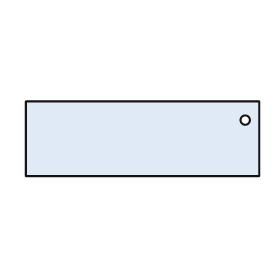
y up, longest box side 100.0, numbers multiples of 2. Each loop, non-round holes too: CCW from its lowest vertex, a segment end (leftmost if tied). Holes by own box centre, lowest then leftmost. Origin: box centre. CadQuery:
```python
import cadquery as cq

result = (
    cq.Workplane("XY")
    .moveTo(-50.0, -16.0)
    .lineTo(50.0, -16.0)
    .lineTo(50.0, 16.0)
    .lineTo(-50.0, 16.0)
    .close()
    .moveTo(44.0, 8.0)
    .circle(2.0)
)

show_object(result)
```